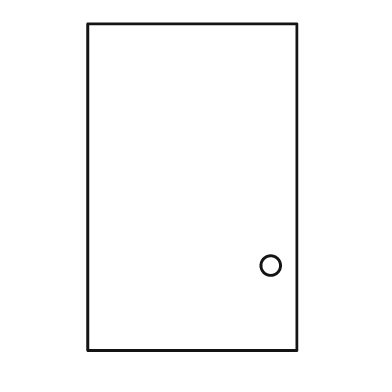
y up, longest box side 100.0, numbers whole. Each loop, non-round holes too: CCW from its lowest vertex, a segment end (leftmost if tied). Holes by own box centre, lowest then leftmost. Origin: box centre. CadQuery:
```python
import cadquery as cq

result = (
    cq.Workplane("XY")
    .moveTo(-32.0, -50.0)
    .lineTo(32.0, -50.0)
    .lineTo(32.0, 50.0)
    .lineTo(-32.0, 50.0)
    .close()
    .moveTo(24.0, -24.0)
    .circle(3.0)
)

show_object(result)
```